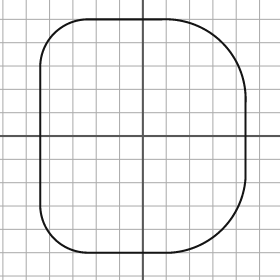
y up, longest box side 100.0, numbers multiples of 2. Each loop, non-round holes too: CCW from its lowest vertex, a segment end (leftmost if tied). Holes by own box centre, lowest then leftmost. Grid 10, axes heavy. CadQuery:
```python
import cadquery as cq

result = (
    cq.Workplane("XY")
    .moveTo(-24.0, -50.0)
    .lineTo(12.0, -50.0)
    .threePointArc((34.0, -40.0), (44.0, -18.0))
    .lineTo(44.0, 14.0)
    .threePointArc((34.0, 40.0), (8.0, 50.0))
    .lineTo(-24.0, 50.0)
    .threePointArc((-38.0, 44.0), (-44.0, 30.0))
    .lineTo(-44.0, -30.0)
    .threePointArc((-38.0, -44.0), (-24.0, -50.0))
    .close()
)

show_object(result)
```